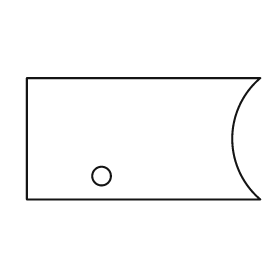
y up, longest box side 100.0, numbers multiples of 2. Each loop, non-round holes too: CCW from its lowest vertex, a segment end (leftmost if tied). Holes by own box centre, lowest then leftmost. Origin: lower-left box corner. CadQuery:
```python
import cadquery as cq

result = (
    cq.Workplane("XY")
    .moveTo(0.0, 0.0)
    .lineTo(100.0, 0.0)
    .threePointArc((88.0, 26.0), (100.0, 52.0))
    .lineTo(0.0, 52.0)
    .close()
    .moveTo(32.0, 10.0)
    .circle(4.0)
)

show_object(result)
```